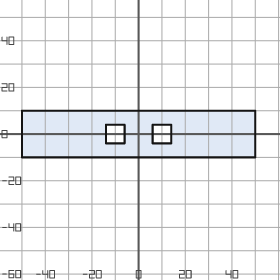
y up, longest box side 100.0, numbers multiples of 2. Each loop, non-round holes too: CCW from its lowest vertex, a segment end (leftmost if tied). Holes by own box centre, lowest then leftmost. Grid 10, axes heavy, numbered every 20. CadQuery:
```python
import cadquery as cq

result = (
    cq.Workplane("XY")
    .moveTo(-50.0, -10.0)
    .lineTo(50.0, -10.0)
    .lineTo(50.0, 10.0)
    .lineTo(-50.0, 10.0)
    .close()
    .moveTo(-14.0, -4.0)
    .lineTo(-6.0, -4.0)
    .lineTo(-6.0, 4.0)
    .lineTo(-14.0, 4.0)
    .close()
    .moveTo(6.0, -4.0)
    .lineTo(14.0, -4.0)
    .lineTo(14.0, 4.0)
    .lineTo(6.0, 4.0)
    .close()
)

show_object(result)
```